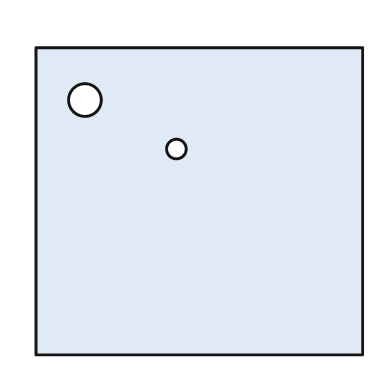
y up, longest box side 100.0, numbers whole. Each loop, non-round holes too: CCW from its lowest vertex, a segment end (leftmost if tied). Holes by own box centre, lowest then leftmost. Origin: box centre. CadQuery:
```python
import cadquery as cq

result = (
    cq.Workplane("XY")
    .moveTo(-50.0, -47.0)
    .lineTo(50.0, -47.0)
    .lineTo(50.0, 47.0)
    .lineTo(-50.0, 47.0)
    .close()
    .moveTo(-7.0, 16.0)
    .circle(3.0)
    .moveTo(-35.0, 31.0)
    .circle(5.0)
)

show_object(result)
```